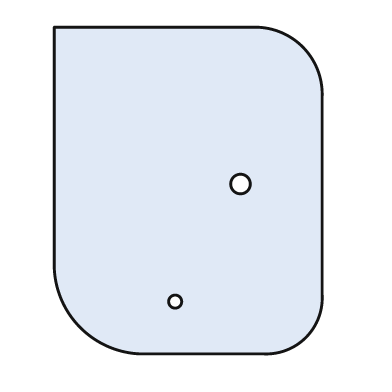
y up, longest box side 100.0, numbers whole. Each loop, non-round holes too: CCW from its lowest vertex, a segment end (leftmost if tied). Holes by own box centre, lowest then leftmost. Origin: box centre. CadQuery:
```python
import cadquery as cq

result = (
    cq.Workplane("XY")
    .moveTo(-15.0, -50.0)
    .lineTo(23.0, -50.0)
    .threePointArc((36.0, -45.0), (41.0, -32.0))
    .lineTo(41.0, 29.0)
    .threePointArc((35.0, 44.0), (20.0, 50.0))
    .lineTo(-41.0, 50.0)
    .lineTo(-41.0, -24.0)
    .threePointArc((-33.0, -42.0), (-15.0, -50.0))
    .close()
    .moveTo(-4.0, -34.0)
    .circle(2.0)
    .moveTo(16.0, 2.0)
    .circle(3.0)
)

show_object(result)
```